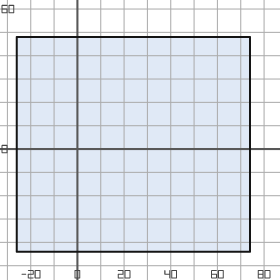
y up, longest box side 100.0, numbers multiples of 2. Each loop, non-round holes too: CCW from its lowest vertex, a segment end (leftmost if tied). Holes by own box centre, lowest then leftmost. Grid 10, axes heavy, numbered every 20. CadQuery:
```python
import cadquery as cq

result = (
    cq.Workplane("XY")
    .moveTo(-26.0, -44.0)
    .lineTo(74.0, -44.0)
    .lineTo(74.0, 48.0)
    .lineTo(-26.0, 48.0)
    .close()
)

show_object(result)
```